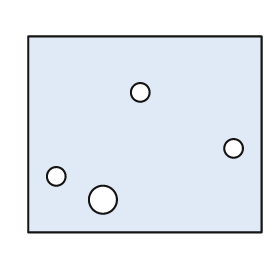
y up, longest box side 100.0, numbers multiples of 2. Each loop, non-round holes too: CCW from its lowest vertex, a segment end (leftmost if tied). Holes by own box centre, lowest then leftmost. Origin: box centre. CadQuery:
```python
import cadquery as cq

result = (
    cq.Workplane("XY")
    .moveTo(-50.0, -42.0)
    .lineTo(50.0, -42.0)
    .lineTo(50.0, 42.0)
    .lineTo(-50.0, 42.0)
    .close()
    .moveTo(-18.0, -28.0)
    .circle(6.0)
    .moveTo(-38.0, -18.0)
    .circle(4.0)
    .moveTo(38.0, -6.0)
    .circle(4.0)
    .moveTo(-2.0, 18.0)
    .circle(4.0)
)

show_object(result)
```